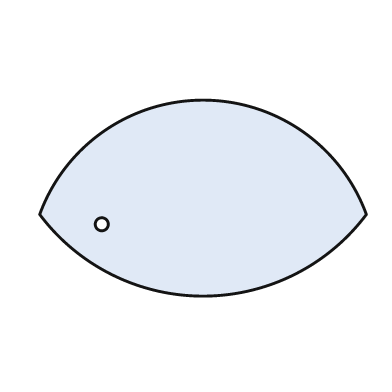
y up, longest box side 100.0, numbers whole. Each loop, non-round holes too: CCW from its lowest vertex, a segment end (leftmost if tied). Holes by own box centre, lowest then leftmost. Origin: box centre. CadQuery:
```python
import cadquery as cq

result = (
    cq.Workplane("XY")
    .moveTo(-50.0, -5.0)
    .threePointArc((0.0, -30.0), (50.0, -5.0))
    .threePointArc((0.0, 30.0), (-50.0, -5.0))
    .close()
    .moveTo(-31.0, -8.0)
    .circle(2.0)
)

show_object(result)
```